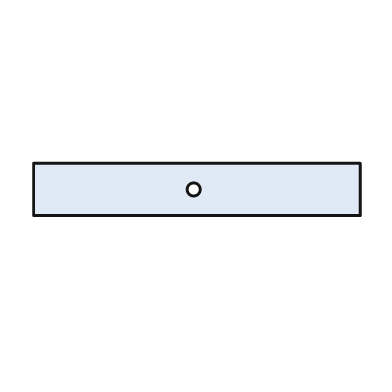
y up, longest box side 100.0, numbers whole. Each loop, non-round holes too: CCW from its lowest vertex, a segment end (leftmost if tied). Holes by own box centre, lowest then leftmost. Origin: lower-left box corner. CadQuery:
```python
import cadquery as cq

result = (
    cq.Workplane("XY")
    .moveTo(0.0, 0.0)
    .lineTo(100.0, 0.0)
    .lineTo(100.0, 16.0)
    .lineTo(0.0, 16.0)
    .close()
    .moveTo(49.0, 8.0)
    .circle(2.0)
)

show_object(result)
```